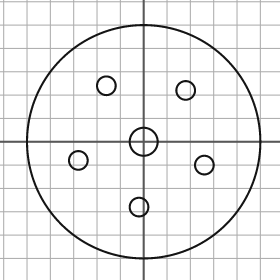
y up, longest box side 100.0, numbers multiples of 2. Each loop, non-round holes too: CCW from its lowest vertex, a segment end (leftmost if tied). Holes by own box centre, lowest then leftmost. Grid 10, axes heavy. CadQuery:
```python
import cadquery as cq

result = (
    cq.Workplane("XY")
    .moveTo(0.0, 0.0)
    .circle(50.0)
    .moveTo(-2.0, -28.0)
    .circle(4.0)
    .moveTo(26.0, -10.0)
    .circle(4.0)
    .moveTo(-28.0, -8.0)
    .circle(4.0)
    .moveTo(0.0, 0.0)
    .circle(6.0)
    .moveTo(18.0, 22.0)
    .circle(4.0)
    .moveTo(-16.0, 24.0)
    .circle(4.0)
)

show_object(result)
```